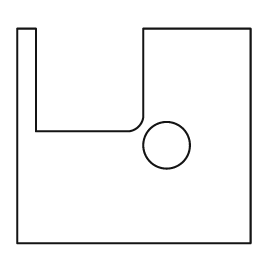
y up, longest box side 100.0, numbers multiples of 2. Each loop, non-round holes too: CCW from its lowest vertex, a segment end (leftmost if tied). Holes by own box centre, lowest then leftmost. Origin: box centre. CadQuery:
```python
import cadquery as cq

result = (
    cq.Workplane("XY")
    .moveTo(-50.0, -46.0)
    .lineTo(50.0, -46.0)
    .lineTo(50.0, 46.0)
    .lineTo(4.0, 46.0)
    .lineTo(4.0, 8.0)
    .threePointArc((2.0, 4.0), (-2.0, 2.0))
    .lineTo(-42.0, 2.0)
    .lineTo(-42.0, 46.0)
    .lineTo(-50.0, 46.0)
    .close()
    .moveTo(14.0, -4.0)
    .circle(10.0)
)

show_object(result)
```